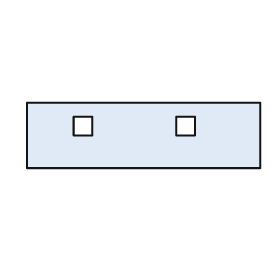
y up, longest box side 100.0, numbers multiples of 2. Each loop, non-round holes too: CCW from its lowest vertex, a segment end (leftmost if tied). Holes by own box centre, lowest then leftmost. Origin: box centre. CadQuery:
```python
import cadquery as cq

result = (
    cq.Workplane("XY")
    .moveTo(-50.0, -14.0)
    .lineTo(50.0, -14.0)
    .lineTo(50.0, 14.0)
    .lineTo(-50.0, 14.0)
    .close()
    .moveTo(-30.0, 0.0)
    .lineTo(-22.0, 0.0)
    .lineTo(-22.0, 8.0)
    .lineTo(-30.0, 8.0)
    .close()
    .moveTo(14.0, 0.0)
    .lineTo(22.0, 0.0)
    .lineTo(22.0, 8.0)
    .lineTo(14.0, 8.0)
    .close()
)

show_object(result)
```